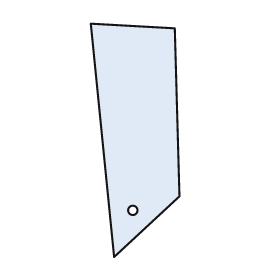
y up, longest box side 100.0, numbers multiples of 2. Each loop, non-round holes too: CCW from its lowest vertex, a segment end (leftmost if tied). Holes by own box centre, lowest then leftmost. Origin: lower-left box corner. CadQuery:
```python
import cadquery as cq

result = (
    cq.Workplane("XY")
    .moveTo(10.0, 0.0)
    .lineTo(38.0, 26.0)
    .lineTo(36.0, 98.0)
    .lineTo(0.0, 100.0)
    .close()
    .moveTo(18.0, 20.0)
    .circle(2.0)
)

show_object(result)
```